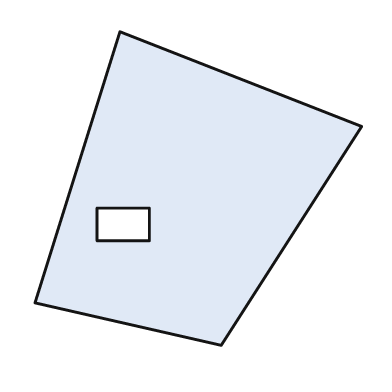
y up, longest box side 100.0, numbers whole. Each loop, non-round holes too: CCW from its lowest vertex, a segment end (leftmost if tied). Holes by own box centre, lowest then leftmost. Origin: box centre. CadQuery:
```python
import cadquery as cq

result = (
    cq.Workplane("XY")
    .moveTo(7.0, -48.0)
    .lineTo(50.0, 19.0)
    .lineTo(-24.0, 48.0)
    .lineTo(-50.0, -35.0)
    .close()
    .moveTo(-31.0, -16.0)
    .lineTo(-15.0, -16.0)
    .lineTo(-15.0, -6.0)
    .lineTo(-31.0, -6.0)
    .close()
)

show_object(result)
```